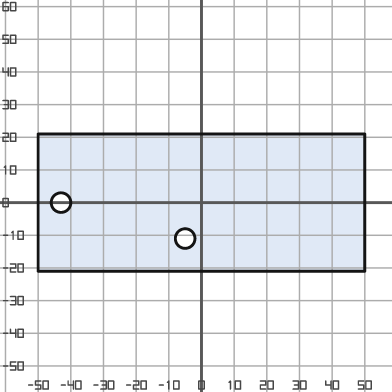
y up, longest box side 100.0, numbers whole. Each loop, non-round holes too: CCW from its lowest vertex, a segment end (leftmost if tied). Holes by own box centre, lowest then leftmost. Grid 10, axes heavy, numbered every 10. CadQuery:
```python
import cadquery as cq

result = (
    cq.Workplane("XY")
    .moveTo(-50.0, -21.0)
    .lineTo(50.0, -21.0)
    .lineTo(50.0, 21.0)
    .lineTo(-50.0, 21.0)
    .close()
    .moveTo(-5.0, -11.0)
    .circle(3.0)
    .moveTo(-43.0, 0.0)
    .circle(3.0)
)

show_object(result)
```